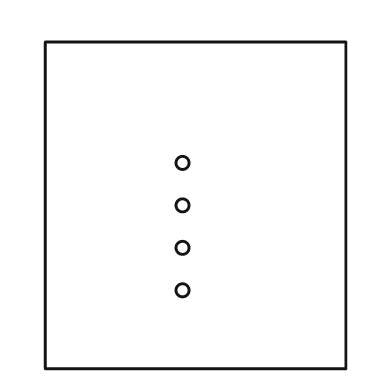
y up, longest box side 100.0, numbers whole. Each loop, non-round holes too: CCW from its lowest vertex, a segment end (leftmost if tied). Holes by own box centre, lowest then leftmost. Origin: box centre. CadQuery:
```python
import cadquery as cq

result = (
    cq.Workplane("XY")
    .moveTo(-46.0, -50.0)
    .lineTo(46.0, -50.0)
    .lineTo(46.0, 50.0)
    .lineTo(-46.0, 50.0)
    .close()
    .moveTo(-4.0, -26.0)
    .circle(2.0)
    .moveTo(-4.0, -13.0)
    .circle(2.0)
    .moveTo(-4.0, 0.0)
    .circle(2.0)
    .moveTo(-4.0, 13.0)
    .circle(2.0)
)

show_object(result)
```